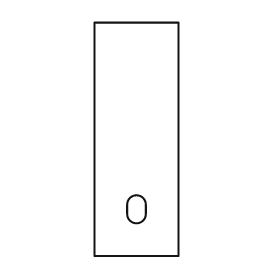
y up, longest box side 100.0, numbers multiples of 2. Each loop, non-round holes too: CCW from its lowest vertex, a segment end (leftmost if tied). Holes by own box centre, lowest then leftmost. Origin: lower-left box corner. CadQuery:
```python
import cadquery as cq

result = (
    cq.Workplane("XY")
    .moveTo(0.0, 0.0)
    .lineTo(36.0, 0.0)
    .lineTo(36.0, 100.0)
    .lineTo(0.0, 100.0)
    .close()
    .moveTo(14.0, 18.0)
    .threePointArc((18.0, 14.0), (22.0, 18.0))
    .lineTo(22.0, 22.0)
    .threePointArc((18.0, 26.0), (14.0, 22.0))
    .close()
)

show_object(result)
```